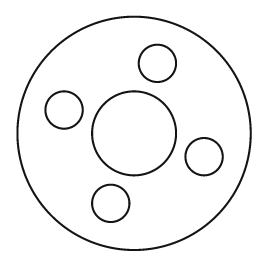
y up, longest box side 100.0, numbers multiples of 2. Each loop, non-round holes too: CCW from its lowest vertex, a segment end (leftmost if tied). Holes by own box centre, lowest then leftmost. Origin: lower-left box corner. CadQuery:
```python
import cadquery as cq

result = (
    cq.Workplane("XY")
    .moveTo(50.0, 50.0)
    .circle(50.0)
    .moveTo(40.0, 20.0)
    .circle(8.0)
    .moveTo(80.0, 40.0)
    .circle(8.0)
    .moveTo(50.0, 50.0)
    .circle(18.0)
    .moveTo(20.0, 60.0)
    .circle(8.0)
    .moveTo(60.0, 80.0)
    .circle(8.0)
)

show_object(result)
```